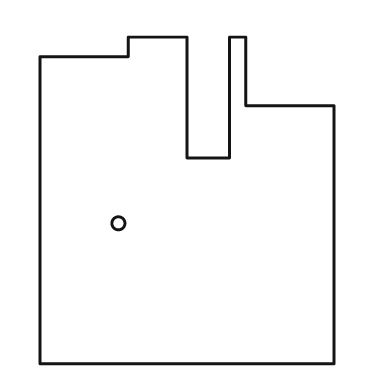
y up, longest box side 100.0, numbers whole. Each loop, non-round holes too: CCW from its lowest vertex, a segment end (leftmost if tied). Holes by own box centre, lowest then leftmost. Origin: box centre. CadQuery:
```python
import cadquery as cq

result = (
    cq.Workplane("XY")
    .moveTo(-45.0, -50.0)
    .lineTo(45.0, -50.0)
    .lineTo(45.0, 29.0)
    .lineTo(18.0, 29.0)
    .lineTo(18.0, 50.0)
    .lineTo(13.0, 50.0)
    .lineTo(13.0, 13.0)
    .lineTo(0.0, 13.0)
    .lineTo(0.0, 50.0)
    .lineTo(-18.0, 50.0)
    .lineTo(-18.0, 44.0)
    .lineTo(-45.0, 44.0)
    .close()
    .moveTo(-21.0, -7.0)
    .circle(2.0)
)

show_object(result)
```